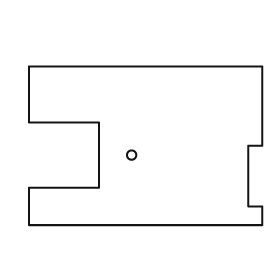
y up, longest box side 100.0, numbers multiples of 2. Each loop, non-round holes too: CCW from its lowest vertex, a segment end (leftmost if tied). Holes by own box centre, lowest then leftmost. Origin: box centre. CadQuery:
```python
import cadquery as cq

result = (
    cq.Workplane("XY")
    .moveTo(-50.0, -34.0)
    .lineTo(50.0, -34.0)
    .lineTo(50.0, -26.0)
    .lineTo(44.0, -26.0)
    .lineTo(44.0, 0.0)
    .lineTo(50.0, 0.0)
    .lineTo(50.0, 34.0)
    .lineTo(-50.0, 34.0)
    .lineTo(-50.0, 10.0)
    .lineTo(-20.0, 10.0)
    .lineTo(-20.0, -18.0)
    .lineTo(-50.0, -18.0)
    .close()
    .moveTo(-6.0, -4.0)
    .circle(2.0)
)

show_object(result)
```